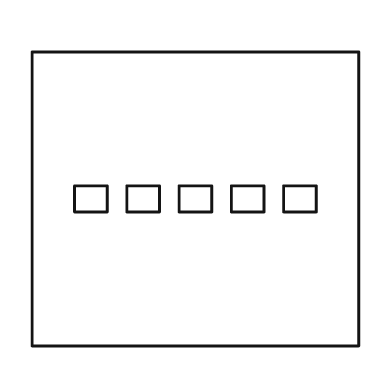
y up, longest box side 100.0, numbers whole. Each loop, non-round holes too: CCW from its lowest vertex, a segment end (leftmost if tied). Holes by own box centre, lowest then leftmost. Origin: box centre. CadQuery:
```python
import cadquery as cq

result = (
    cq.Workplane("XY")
    .moveTo(-50.0, -45.0)
    .lineTo(50.0, -45.0)
    .lineTo(50.0, 45.0)
    .lineTo(-50.0, 45.0)
    .close()
    .moveTo(-37.0, -4.0)
    .lineTo(-27.0, -4.0)
    .lineTo(-27.0, 4.0)
    .lineTo(-37.0, 4.0)
    .close()
    .moveTo(-21.0, -4.0)
    .lineTo(-11.0, -4.0)
    .lineTo(-11.0, 4.0)
    .lineTo(-21.0, 4.0)
    .close()
    .moveTo(-5.0, -4.0)
    .lineTo(5.0, -4.0)
    .lineTo(5.0, 4.0)
    .lineTo(-5.0, 4.0)
    .close()
    .moveTo(11.0, -4.0)
    .lineTo(21.0, -4.0)
    .lineTo(21.0, 4.0)
    .lineTo(11.0, 4.0)
    .close()
    .moveTo(27.0, -4.0)
    .lineTo(37.0, -4.0)
    .lineTo(37.0, 4.0)
    .lineTo(27.0, 4.0)
    .close()
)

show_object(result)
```